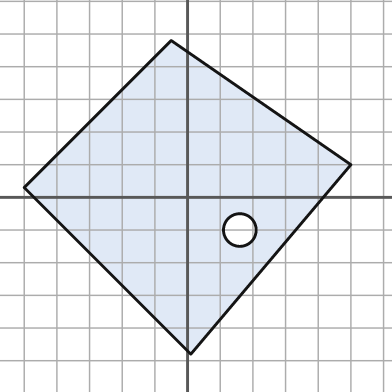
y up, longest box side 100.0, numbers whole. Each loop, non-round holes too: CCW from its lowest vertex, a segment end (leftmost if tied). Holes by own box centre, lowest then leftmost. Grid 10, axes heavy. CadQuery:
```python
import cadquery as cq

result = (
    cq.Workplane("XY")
    .moveTo(1.0, -48.0)
    .lineTo(50.0, 10.0)
    .lineTo(-5.0, 48.0)
    .lineTo(-50.0, 3.0)
    .close()
    .moveTo(16.0, -10.0)
    .circle(5.0)
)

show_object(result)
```